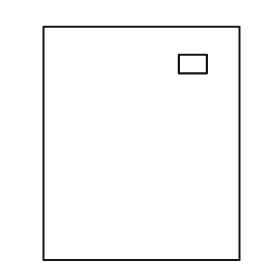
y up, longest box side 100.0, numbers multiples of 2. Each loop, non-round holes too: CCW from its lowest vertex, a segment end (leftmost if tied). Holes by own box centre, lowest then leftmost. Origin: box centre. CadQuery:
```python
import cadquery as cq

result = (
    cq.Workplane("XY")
    .moveTo(-42.0, -50.0)
    .lineTo(42.0, -50.0)
    .lineTo(42.0, 50.0)
    .lineTo(-42.0, 50.0)
    .close()
    .moveTo(16.0, 30.0)
    .lineTo(28.0, 30.0)
    .lineTo(28.0, 38.0)
    .lineTo(16.0, 38.0)
    .close()
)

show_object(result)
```